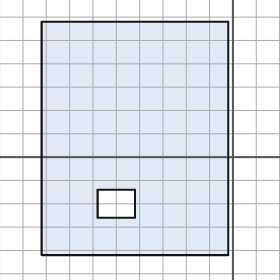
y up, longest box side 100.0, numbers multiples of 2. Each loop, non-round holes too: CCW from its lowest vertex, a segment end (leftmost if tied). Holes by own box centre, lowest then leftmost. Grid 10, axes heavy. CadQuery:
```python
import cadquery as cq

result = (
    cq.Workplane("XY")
    .moveTo(-82.0, -42.0)
    .lineTo(-2.0, -42.0)
    .lineTo(-2.0, 58.0)
    .lineTo(-82.0, 58.0)
    .close()
    .moveTo(-58.0, -26.0)
    .lineTo(-42.0, -26.0)
    .lineTo(-42.0, -14.0)
    .lineTo(-58.0, -14.0)
    .close()
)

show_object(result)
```